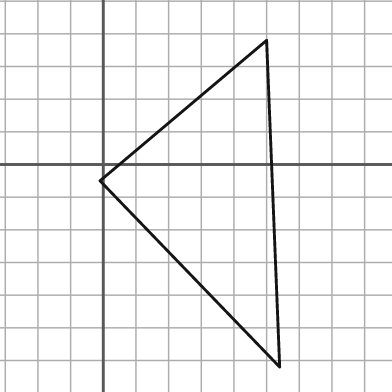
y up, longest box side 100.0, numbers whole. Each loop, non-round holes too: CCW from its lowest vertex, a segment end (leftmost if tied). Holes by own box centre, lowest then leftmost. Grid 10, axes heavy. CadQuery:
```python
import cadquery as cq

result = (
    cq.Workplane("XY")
    .moveTo(54.0, -62.0)
    .lineTo(50.0, 38.0)
    .lineTo(-1.0, -5.0)
    .close()
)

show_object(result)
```